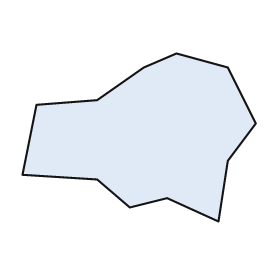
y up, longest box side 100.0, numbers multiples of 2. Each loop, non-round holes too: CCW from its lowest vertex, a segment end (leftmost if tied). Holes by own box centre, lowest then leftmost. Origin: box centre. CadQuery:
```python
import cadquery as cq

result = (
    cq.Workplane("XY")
    .moveTo(34.0, -36.0)
    .lineTo(38.0, -10.0)
    .lineTo(50.0, 6.0)
    .lineTo(38.0, 30.0)
    .lineTo(16.0, 36.0)
    .lineTo(2.0, 30.0)
    .lineTo(-18.0, 16.0)
    .lineTo(-44.0, 14.0)
    .lineTo(-50.0, -16.0)
    .lineTo(-18.0, -18.0)
    .lineTo(-4.0, -30.0)
    .lineTo(12.0, -26.0)
    .close()
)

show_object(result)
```